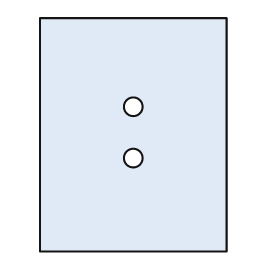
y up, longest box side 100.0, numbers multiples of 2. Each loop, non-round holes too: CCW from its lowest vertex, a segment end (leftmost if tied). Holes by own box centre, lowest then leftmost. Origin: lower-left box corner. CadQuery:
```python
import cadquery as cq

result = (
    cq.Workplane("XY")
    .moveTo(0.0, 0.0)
    .lineTo(80.0, 0.0)
    .lineTo(80.0, 100.0)
    .lineTo(0.0, 100.0)
    .close()
    .moveTo(40.0, 40.0)
    .circle(4.0)
    .moveTo(40.0, 62.0)
    .circle(4.0)
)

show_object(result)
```